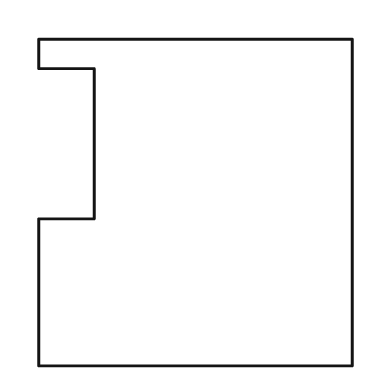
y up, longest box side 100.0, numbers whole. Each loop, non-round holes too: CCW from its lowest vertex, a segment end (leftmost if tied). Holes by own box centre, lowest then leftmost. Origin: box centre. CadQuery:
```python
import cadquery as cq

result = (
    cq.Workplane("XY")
    .moveTo(-48.0, -50.0)
    .lineTo(48.0, -50.0)
    .lineTo(48.0, 50.0)
    .lineTo(-48.0, 50.0)
    .lineTo(-48.0, 41.0)
    .lineTo(-31.0, 41.0)
    .lineTo(-31.0, -5.0)
    .lineTo(-48.0, -5.0)
    .close()
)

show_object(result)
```